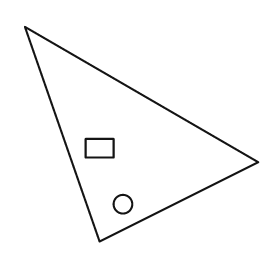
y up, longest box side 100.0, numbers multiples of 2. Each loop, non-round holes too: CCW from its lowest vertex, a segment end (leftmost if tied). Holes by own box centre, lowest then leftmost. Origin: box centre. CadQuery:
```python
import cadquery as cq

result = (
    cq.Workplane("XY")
    .moveTo(-18.0, -46.0)
    .lineTo(50.0, -12.0)
    .lineTo(-50.0, 46.0)
    .close()
    .moveTo(-8.0, -30.0)
    .circle(4.0)
    .moveTo(-24.0, -10.0)
    .lineTo(-12.0, -10.0)
    .lineTo(-12.0, -2.0)
    .lineTo(-24.0, -2.0)
    .close()
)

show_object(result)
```